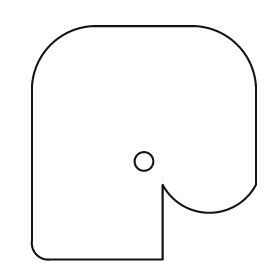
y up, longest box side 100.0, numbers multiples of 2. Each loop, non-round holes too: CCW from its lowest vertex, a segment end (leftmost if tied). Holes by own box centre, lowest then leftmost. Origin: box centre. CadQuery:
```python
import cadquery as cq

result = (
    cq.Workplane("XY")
    .moveTo(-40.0, -50.0)
    .lineTo(8.0, -50.0)
    .lineTo(8.0, -18.0)
    .threePointArc((28.0, -30.0), (48.0, -18.0))
    .lineTo(48.0, 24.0)
    .threePointArc((40.0, 42.0), (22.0, 50.0))
    .lineTo(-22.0, 50.0)
    .threePointArc((-40.0, 42.0), (-48.0, 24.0))
    .lineTo(-48.0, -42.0)
    .threePointArc((-46.0, -48.0), (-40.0, -50.0))
    .close()
    .moveTo(0.0, -8.0)
    .circle(4.0)
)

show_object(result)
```